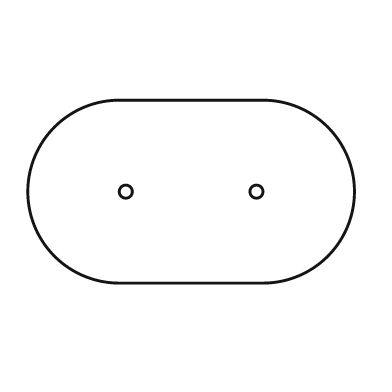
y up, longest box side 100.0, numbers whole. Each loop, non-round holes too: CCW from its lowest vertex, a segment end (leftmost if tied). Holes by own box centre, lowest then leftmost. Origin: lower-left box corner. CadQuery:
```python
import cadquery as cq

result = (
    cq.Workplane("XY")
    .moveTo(28.0, 0.0)
    .lineTo(72.0, 0.0)
    .threePointArc((100.0, 28.0), (72.0, 56.0))
    .lineTo(28.0, 56.0)
    .threePointArc((0.0, 28.0), (28.0, 0.0))
    .close()
    .moveTo(30.0, 28.0)
    .circle(2.0)
    .moveTo(70.0, 28.0)
    .circle(2.0)
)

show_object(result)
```